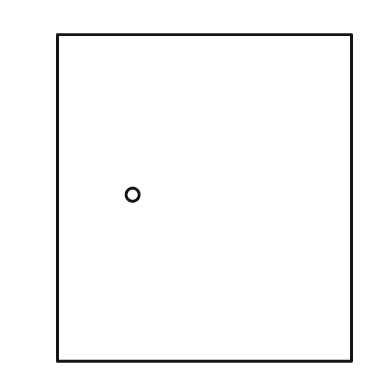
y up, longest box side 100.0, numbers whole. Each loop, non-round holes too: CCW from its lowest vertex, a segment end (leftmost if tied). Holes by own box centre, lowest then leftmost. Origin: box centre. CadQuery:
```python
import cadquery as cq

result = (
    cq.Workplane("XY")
    .moveTo(-45.0, -50.0)
    .lineTo(45.0, -50.0)
    .lineTo(45.0, 50.0)
    .lineTo(-45.0, 50.0)
    .close()
    .moveTo(-22.0, 1.0)
    .circle(2.0)
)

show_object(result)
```